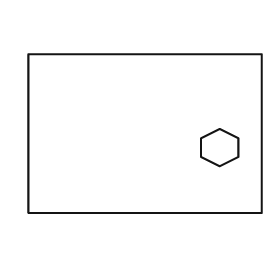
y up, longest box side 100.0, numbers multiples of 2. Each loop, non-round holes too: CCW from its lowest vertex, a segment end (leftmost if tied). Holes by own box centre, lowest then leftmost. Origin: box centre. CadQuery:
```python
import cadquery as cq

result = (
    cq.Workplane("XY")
    .moveTo(-50.0, -34.0)
    .lineTo(50.0, -34.0)
    .lineTo(50.0, 34.0)
    .lineTo(-50.0, 34.0)
    .close()
    .moveTo(32.0, -14.0)
    .lineTo(40.0, -10.0)
    .lineTo(40.0, -2.0)
    .lineTo(32.0, 2.0)
    .lineTo(24.0, -2.0)
    .lineTo(24.0, -10.0)
    .close()
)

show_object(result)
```